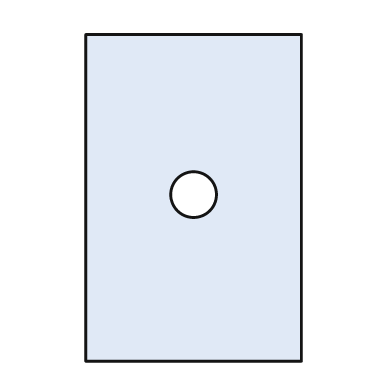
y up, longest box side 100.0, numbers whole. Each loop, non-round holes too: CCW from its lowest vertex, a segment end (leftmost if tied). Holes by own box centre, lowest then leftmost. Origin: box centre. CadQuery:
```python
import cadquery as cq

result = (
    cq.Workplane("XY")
    .moveTo(-33.0, -50.0)
    .lineTo(33.0, -50.0)
    .lineTo(33.0, 50.0)
    .lineTo(-33.0, 50.0)
    .close()
    .moveTo(0.0, 1.0)
    .circle(7.0)
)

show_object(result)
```